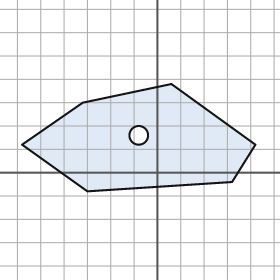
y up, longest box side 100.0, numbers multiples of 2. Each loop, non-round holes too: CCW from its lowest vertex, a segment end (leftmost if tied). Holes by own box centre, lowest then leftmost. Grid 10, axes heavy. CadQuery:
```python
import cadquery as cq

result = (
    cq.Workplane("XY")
    .moveTo(-30.0, -8.0)
    .lineTo(32.0, -4.0)
    .lineTo(42.0, 12.0)
    .lineTo(6.0, 38.0)
    .lineTo(-32.0, 30.0)
    .lineTo(-58.0, 12.0)
    .close()
    .moveTo(-8.0, 16.0)
    .circle(4.0)
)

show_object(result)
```